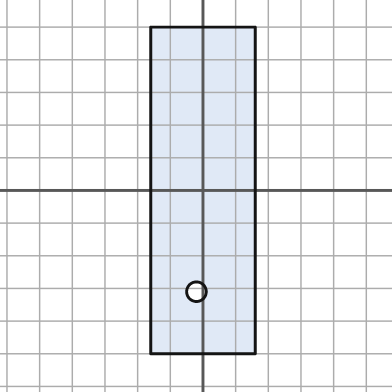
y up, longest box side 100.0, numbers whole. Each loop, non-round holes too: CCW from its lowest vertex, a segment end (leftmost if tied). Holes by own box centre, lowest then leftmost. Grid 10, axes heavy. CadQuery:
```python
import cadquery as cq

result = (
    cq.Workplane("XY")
    .moveTo(-16.0, -50.0)
    .lineTo(16.0, -50.0)
    .lineTo(16.0, 50.0)
    .lineTo(-16.0, 50.0)
    .close()
    .moveTo(-2.0, -31.0)
    .circle(3.0)
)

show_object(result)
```